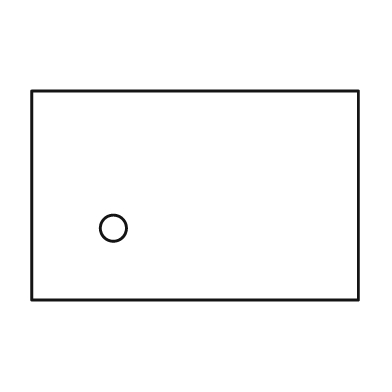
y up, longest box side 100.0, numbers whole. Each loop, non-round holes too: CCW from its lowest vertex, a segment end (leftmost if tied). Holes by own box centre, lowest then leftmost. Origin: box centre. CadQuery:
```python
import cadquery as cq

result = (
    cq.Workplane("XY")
    .moveTo(-50.0, -32.0)
    .lineTo(50.0, -32.0)
    .lineTo(50.0, 32.0)
    .lineTo(-50.0, 32.0)
    .close()
    .moveTo(-25.0, -10.0)
    .circle(4.0)
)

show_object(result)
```